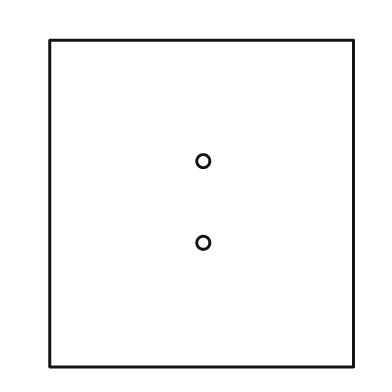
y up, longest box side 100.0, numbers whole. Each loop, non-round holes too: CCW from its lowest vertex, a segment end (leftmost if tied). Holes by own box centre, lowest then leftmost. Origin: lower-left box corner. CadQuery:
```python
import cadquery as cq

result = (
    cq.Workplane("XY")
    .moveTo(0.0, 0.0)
    .lineTo(93.0, 0.0)
    .lineTo(93.0, 100.0)
    .lineTo(0.0, 100.0)
    .close()
    .moveTo(47.0, 38.0)
    .circle(2.0)
    .moveTo(47.0, 63.0)
    .circle(2.0)
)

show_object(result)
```